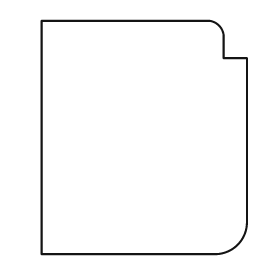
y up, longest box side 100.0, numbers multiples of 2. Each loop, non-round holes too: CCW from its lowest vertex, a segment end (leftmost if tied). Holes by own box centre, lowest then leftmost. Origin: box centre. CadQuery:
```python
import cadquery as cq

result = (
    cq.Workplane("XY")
    .moveTo(-44.0, -50.0)
    .lineTo(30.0, -50.0)
    .threePointArc((40.0, -46.0), (44.0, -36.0))
    .lineTo(44.0, 34.0)
    .lineTo(34.0, 34.0)
    .lineTo(34.0, 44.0)
    .threePointArc((32.0, 48.0), (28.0, 50.0))
    .lineTo(-44.0, 50.0)
    .close()
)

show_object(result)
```